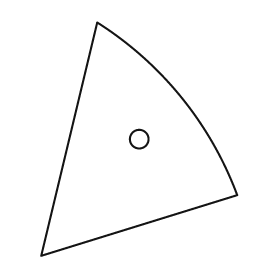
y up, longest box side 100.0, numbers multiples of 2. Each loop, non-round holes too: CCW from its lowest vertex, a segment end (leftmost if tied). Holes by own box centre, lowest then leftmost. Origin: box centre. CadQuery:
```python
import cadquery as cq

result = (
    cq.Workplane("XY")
    .moveTo(-42.0, -50.0)
    .lineTo(42.0, -24.0)
    .threePointArc((18.0, 18.0), (-18.0, 50.0))
    .close()
    .moveTo(0.0, 0.0)
    .circle(4.0)
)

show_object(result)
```